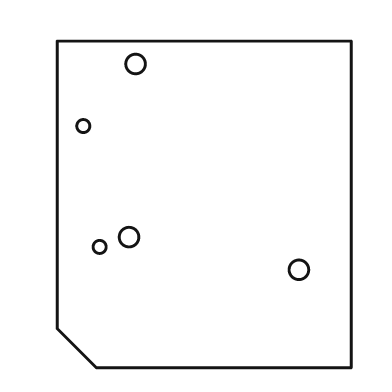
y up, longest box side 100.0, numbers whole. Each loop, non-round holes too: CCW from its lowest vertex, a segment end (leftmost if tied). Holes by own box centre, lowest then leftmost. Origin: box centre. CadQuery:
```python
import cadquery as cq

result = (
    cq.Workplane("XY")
    .moveTo(-33.0, -50.0)
    .lineTo(45.0, -50.0)
    .lineTo(45.0, 50.0)
    .lineTo(-45.0, 50.0)
    .lineTo(-45.0, -38.0)
    .close()
    .moveTo(29.0, -20.0)
    .circle(3.0)
    .moveTo(-32.0, -13.0)
    .circle(2.0)
    .moveTo(-23.0, -10.0)
    .circle(3.0)
    .moveTo(-37.0, 24.0)
    .circle(2.0)
    .moveTo(-21.0, 43.0)
    .circle(3.0)
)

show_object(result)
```